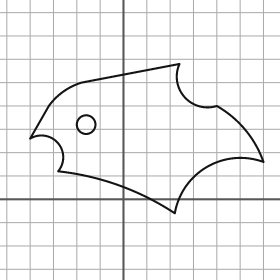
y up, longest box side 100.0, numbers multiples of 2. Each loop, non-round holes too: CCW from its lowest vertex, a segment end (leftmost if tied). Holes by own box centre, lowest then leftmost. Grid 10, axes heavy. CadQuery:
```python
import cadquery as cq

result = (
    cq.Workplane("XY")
    .moveTo(22.0, -6.0)
    .threePointArc((36.0, 14.0), (60.0, 16.0))
    .threePointArc((52.0, 30.0), (40.0, 40.0))
    .threePointArc((26.0, 44.0), (24.0, 58.0))
    .lineTo(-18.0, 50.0)
    .threePointArc((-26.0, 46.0), (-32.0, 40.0))
    .lineTo(-40.0, 26.0)
    .threePointArc((-28.0, 24.0), (-28.0, 12.0))
    .threePointArc((-2.0, 6.0), (22.0, -6.0))
    .close()
    .moveTo(-16.0, 32.0)
    .circle(4.0)
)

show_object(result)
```